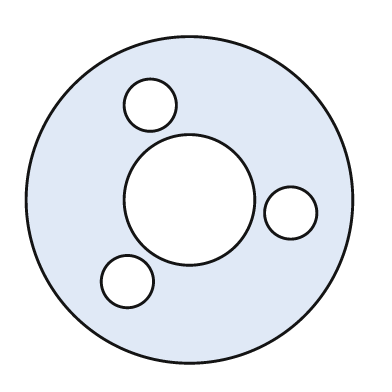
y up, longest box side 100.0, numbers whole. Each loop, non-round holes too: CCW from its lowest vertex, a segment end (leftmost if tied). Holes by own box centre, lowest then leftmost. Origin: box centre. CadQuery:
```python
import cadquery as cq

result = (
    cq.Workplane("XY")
    .moveTo(0.0, 0.0)
    .circle(50.0)
    .moveTo(-19.0, -25.0)
    .circle(8.0)
    .moveTo(31.0, -4.0)
    .circle(8.0)
    .moveTo(0.0, 0.0)
    .circle(20.0)
    .moveTo(-12.0, 29.0)
    .circle(8.0)
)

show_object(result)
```